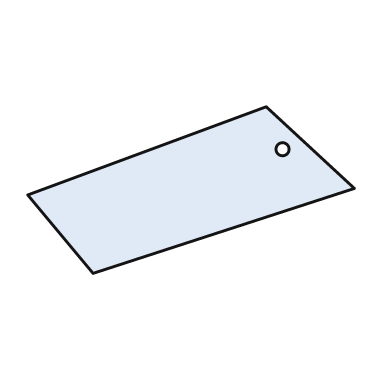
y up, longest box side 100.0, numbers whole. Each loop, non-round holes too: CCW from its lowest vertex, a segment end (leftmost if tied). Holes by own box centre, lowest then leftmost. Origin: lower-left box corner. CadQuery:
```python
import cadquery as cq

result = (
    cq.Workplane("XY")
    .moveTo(20.0, 0.0)
    .lineTo(100.0, 26.0)
    .lineTo(73.0, 51.0)
    .lineTo(0.0, 24.0)
    .close()
    .moveTo(78.0, 38.0)
    .circle(2.0)
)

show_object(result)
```